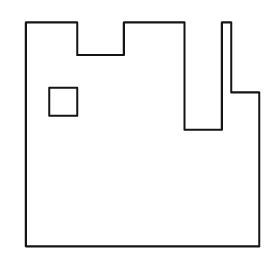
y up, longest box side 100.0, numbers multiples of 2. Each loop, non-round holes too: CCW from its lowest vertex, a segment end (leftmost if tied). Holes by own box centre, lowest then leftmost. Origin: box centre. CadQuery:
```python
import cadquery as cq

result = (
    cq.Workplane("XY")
    .moveTo(-50.0, -48.0)
    .lineTo(50.0, -48.0)
    .lineTo(50.0, 18.0)
    .lineTo(38.0, 18.0)
    .lineTo(38.0, 48.0)
    .lineTo(34.0, 48.0)
    .lineTo(34.0, 2.0)
    .lineTo(18.0, 2.0)
    .lineTo(18.0, 48.0)
    .lineTo(-8.0, 48.0)
    .lineTo(-8.0, 34.0)
    .lineTo(-28.0, 34.0)
    .lineTo(-28.0, 48.0)
    .lineTo(-50.0, 48.0)
    .close()
    .moveTo(-40.0, 8.0)
    .lineTo(-28.0, 8.0)
    .lineTo(-28.0, 20.0)
    .lineTo(-40.0, 20.0)
    .close()
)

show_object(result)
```